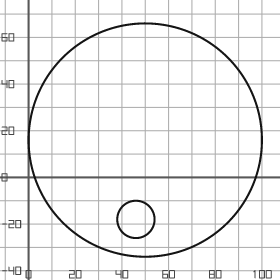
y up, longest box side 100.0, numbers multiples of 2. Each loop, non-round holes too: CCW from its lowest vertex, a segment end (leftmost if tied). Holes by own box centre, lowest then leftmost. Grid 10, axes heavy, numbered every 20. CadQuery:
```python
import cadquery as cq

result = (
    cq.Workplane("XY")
    .moveTo(50.0, 16.0)
    .circle(50.0)
    .moveTo(46.0, -18.0)
    .circle(8.0)
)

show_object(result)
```